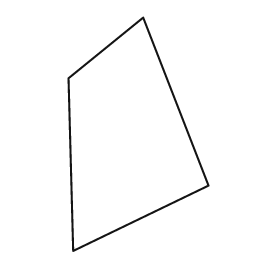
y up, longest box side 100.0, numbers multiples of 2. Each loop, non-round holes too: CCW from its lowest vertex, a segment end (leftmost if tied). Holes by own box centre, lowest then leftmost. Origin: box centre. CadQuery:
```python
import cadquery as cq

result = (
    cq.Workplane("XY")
    .moveTo(-28.0, -50.0)
    .lineTo(30.0, -22.0)
    .lineTo(2.0, 50.0)
    .lineTo(-30.0, 24.0)
    .close()
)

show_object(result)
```